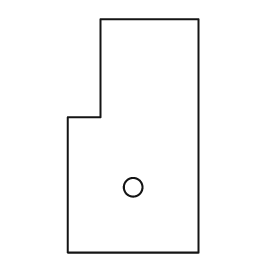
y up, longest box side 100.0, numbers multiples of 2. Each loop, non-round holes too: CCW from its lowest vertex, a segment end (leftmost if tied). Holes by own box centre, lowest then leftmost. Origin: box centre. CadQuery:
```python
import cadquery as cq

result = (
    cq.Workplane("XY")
    .moveTo(-28.0, -50.0)
    .lineTo(28.0, -50.0)
    .lineTo(28.0, 50.0)
    .lineTo(-14.0, 50.0)
    .lineTo(-14.0, 8.0)
    .lineTo(-28.0, 8.0)
    .close()
    .moveTo(0.0, -22.0)
    .circle(4.0)
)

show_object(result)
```